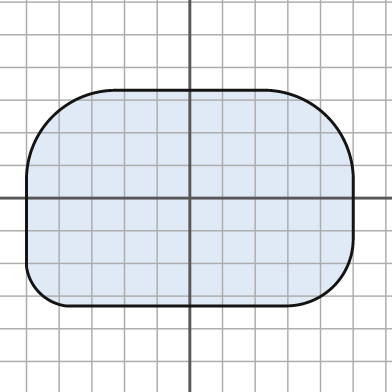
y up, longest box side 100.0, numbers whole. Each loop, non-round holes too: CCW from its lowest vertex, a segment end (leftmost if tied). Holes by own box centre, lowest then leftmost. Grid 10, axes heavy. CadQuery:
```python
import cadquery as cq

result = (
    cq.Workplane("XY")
    .moveTo(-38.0, -33.0)
    .lineTo(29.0, -33.0)
    .threePointArc((44.0, -27.0), (50.0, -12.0))
    .lineTo(50.0, 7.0)
    .threePointArc((42.0, 25.0), (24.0, 33.0))
    .lineTo(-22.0, 33.0)
    .threePointArc((-42.0, 25.0), (-50.0, 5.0))
    .lineTo(-50.0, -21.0)
    .threePointArc((-46.0, -29.0), (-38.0, -33.0))
    .close()
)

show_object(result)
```